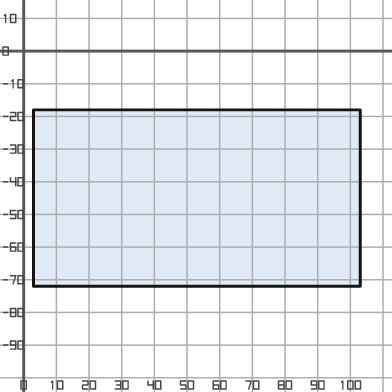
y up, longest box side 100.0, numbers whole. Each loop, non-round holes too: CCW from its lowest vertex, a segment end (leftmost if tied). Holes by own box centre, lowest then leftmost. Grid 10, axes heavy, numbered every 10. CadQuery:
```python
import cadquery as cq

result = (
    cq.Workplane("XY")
    .moveTo(3.0, -72.0)
    .lineTo(103.0, -72.0)
    .lineTo(103.0, -18.0)
    .lineTo(3.0, -18.0)
    .close()
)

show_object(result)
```